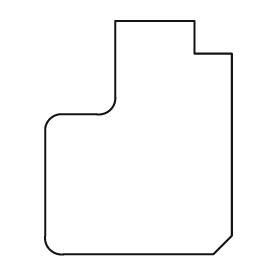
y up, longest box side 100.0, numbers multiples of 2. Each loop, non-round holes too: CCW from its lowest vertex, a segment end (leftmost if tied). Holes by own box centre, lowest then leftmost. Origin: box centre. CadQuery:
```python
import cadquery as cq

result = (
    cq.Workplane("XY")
    .moveTo(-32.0, -50.0)
    .lineTo(32.0, -50.0)
    .lineTo(40.0, -42.0)
    .lineTo(40.0, 36.0)
    .lineTo(24.0, 36.0)
    .lineTo(24.0, 50.0)
    .lineTo(-10.0, 50.0)
    .lineTo(-10.0, 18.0)
    .threePointArc((-12.0, 12.0), (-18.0, 10.0))
    .lineTo(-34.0, 10.0)
    .threePointArc((-38.0, 8.0), (-40.0, 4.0))
    .lineTo(-40.0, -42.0)
    .threePointArc((-38.0, -48.0), (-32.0, -50.0))
    .close()
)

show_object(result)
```